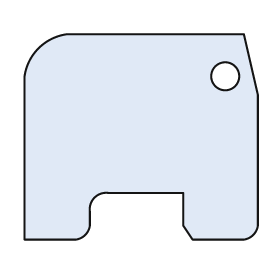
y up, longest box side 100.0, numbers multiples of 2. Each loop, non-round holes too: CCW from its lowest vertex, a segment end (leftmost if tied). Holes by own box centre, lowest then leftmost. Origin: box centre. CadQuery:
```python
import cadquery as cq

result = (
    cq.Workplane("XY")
    .moveTo(-50.0, -44.0)
    .lineTo(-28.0, -44.0)
    .threePointArc((-24.0, -42.0), (-22.0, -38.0))
    .lineTo(-22.0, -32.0)
    .threePointArc((-20.0, -26.0), (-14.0, -24.0))
    .lineTo(18.0, -24.0)
    .lineTo(18.0, -38.0)
    .lineTo(22.0, -44.0)
    .lineTo(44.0, -44.0)
    .threePointArc((48.0, -42.0), (50.0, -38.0))
    .lineTo(50.0, 18.0)
    .lineTo(44.0, 44.0)
    .lineTo(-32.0, 44.0)
    .threePointArc((-44.0, 38.0), (-50.0, 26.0))
    .close()
    .moveTo(36.0, 26.0)
    .circle(6.0)
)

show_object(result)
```